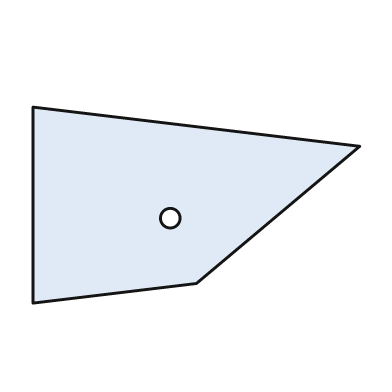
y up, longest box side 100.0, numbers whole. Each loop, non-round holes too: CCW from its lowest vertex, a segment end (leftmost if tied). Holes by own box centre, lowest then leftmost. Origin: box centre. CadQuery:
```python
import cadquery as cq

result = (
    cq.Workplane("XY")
    .moveTo(-50.0, -30.0)
    .lineTo(0.0, -24.0)
    .lineTo(50.0, 18.0)
    .lineTo(-50.0, 30.0)
    .close()
    .moveTo(-8.0, -4.0)
    .circle(3.0)
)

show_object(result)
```